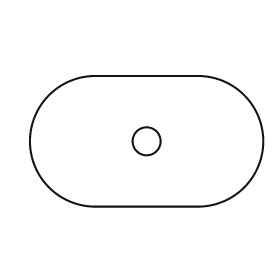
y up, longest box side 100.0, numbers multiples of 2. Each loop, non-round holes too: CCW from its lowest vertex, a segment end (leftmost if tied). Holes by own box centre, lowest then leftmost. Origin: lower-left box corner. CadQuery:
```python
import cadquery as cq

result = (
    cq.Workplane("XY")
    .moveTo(28.0, 0.0)
    .lineTo(72.0, 0.0)
    .threePointArc((100.0, 28.0), (72.0, 56.0))
    .lineTo(28.0, 56.0)
    .threePointArc((0.0, 28.0), (28.0, 0.0))
    .close()
    .moveTo(50.0, 28.0)
    .circle(6.0)
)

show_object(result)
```